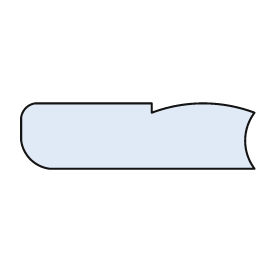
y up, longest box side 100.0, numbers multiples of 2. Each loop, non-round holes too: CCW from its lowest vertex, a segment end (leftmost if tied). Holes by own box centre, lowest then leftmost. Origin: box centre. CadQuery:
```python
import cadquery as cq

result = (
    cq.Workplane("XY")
    .moveTo(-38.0, -14.0)
    .lineTo(50.0, -14.0)
    .threePointArc((46.0, -2.0), (50.0, 10.0))
    .threePointArc((28.0, 14.0), (6.0, 10.0))
    .lineTo(6.0, 14.0)
    .lineTo(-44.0, 14.0)
    .threePointArc((-48.0, 12.0), (-50.0, 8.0))
    .lineTo(-50.0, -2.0)
    .threePointArc((-46.0, -10.0), (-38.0, -14.0))
    .close()
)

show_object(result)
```